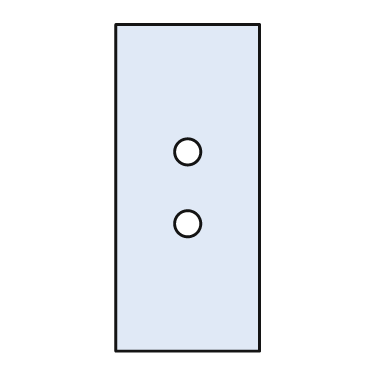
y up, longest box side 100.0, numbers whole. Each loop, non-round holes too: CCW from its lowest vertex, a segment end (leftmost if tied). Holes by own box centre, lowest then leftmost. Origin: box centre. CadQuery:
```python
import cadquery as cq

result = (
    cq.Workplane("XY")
    .moveTo(-22.0, -50.0)
    .lineTo(22.0, -50.0)
    .lineTo(22.0, 50.0)
    .lineTo(-22.0, 50.0)
    .close()
    .moveTo(0.0, -11.0)
    .circle(4.0)
    .moveTo(0.0, 11.0)
    .circle(4.0)
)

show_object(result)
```